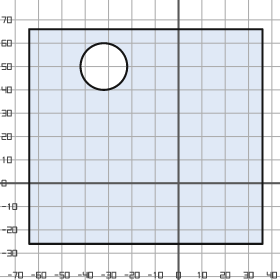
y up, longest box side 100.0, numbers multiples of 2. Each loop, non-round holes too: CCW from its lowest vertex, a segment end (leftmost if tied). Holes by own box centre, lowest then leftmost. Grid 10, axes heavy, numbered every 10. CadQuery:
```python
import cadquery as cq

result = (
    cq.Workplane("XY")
    .moveTo(-64.0, -26.0)
    .lineTo(36.0, -26.0)
    .lineTo(36.0, 66.0)
    .lineTo(-64.0, 66.0)
    .close()
    .moveTo(-32.0, 50.0)
    .circle(10.0)
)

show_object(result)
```